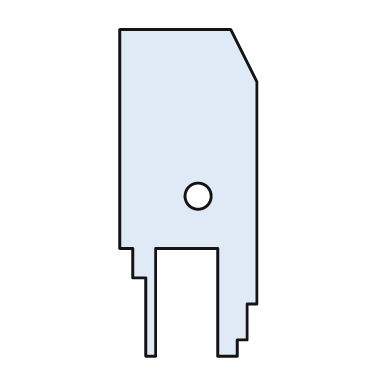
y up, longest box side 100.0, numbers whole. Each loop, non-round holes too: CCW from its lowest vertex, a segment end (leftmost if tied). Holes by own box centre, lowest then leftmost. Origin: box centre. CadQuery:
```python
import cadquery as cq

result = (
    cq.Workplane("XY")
    .moveTo(-13.0, -50.0)
    .lineTo(-10.0, -50.0)
    .lineTo(-10.0, -17.0)
    .lineTo(9.0, -17.0)
    .lineTo(9.0, -50.0)
    .lineTo(15.0, -50.0)
    .lineTo(15.0, -45.0)
    .lineTo(18.0, -45.0)
    .lineTo(18.0, -34.0)
    .lineTo(21.0, -34.0)
    .lineTo(21.0, 34.0)
    .lineTo(13.0, 50.0)
    .lineTo(-21.0, 50.0)
    .lineTo(-21.0, -17.0)
    .lineTo(-17.0, -17.0)
    .lineTo(-17.0, -26.0)
    .lineTo(-13.0, -26.0)
    .close()
    .moveTo(3.0, -1.0)
    .circle(4.0)
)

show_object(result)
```